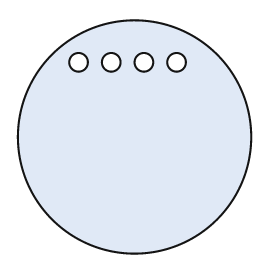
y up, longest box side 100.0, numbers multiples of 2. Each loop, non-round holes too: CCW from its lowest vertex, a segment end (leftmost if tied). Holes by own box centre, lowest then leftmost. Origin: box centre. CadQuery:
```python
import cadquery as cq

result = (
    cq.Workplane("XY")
    .moveTo(0.0, 0.0)
    .circle(50.0)
    .moveTo(-24.0, 32.0)
    .circle(4.0)
    .moveTo(-10.0, 32.0)
    .circle(4.0)
    .moveTo(4.0, 32.0)
    .circle(4.0)
    .moveTo(18.0, 32.0)
    .circle(4.0)
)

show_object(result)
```